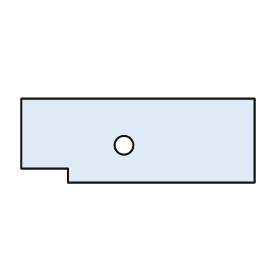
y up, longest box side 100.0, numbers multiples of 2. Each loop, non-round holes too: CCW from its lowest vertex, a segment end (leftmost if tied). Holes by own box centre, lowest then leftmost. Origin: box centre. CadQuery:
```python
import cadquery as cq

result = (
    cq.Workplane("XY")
    .moveTo(-30.0, -18.0)
    .lineTo(50.0, -18.0)
    .lineTo(50.0, 18.0)
    .lineTo(-50.0, 18.0)
    .lineTo(-50.0, -12.0)
    .lineTo(-30.0, -12.0)
    .close()
    .moveTo(-6.0, -2.0)
    .circle(4.0)
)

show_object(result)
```